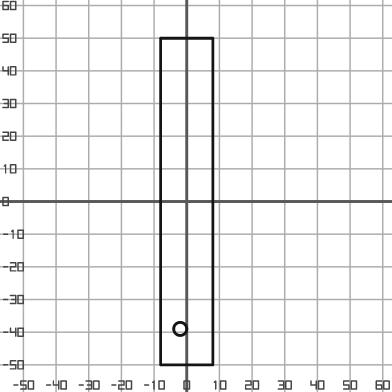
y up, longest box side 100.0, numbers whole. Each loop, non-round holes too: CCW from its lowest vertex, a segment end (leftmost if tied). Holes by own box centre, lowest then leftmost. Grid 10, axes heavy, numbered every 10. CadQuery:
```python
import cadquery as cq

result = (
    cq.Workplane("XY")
    .moveTo(-8.0, -50.0)
    .lineTo(8.0, -50.0)
    .lineTo(8.0, 50.0)
    .lineTo(-8.0, 50.0)
    .close()
    .moveTo(-2.0, -39.0)
    .circle(2.0)
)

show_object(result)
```